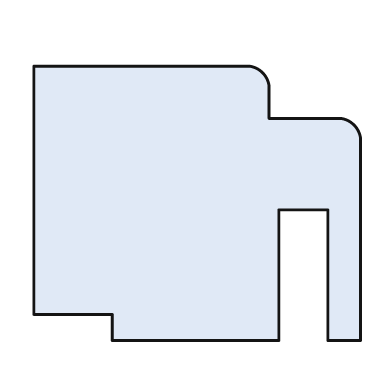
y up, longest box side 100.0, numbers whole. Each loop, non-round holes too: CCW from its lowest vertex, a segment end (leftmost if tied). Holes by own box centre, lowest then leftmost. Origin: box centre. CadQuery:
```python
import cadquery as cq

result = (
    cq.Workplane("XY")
    .moveTo(-26.0, -42.0)
    .lineTo(25.0, -42.0)
    .lineTo(25.0, -2.0)
    .lineTo(40.0, -2.0)
    .lineTo(40.0, -42.0)
    .lineTo(50.0, -42.0)
    .lineTo(50.0, 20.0)
    .threePointArc((48.0, 24.0), (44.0, 26.0))
    .lineTo(22.0, 26.0)
    .lineTo(22.0, 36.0)
    .threePointArc((20.0, 40.0), (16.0, 42.0))
    .lineTo(-50.0, 42.0)
    .lineTo(-50.0, -34.0)
    .lineTo(-26.0, -34.0)
    .close()
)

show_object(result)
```